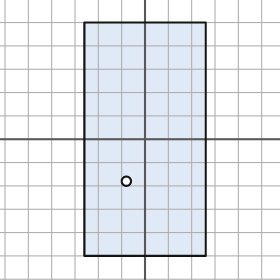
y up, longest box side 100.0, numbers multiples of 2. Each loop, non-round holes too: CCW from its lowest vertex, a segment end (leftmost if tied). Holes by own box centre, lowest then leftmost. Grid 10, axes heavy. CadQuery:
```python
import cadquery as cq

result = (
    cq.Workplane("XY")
    .moveTo(-26.0, -50.0)
    .lineTo(26.0, -50.0)
    .lineTo(26.0, 50.0)
    .lineTo(-26.0, 50.0)
    .close()
    .moveTo(-8.0, -18.0)
    .circle(2.0)
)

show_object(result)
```